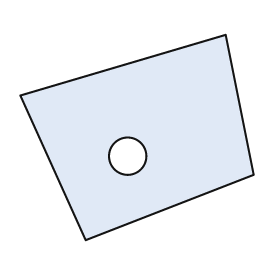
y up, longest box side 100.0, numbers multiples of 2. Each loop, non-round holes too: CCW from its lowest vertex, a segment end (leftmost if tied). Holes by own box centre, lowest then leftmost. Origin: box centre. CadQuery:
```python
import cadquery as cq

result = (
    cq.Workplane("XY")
    .moveTo(-22.0, -44.0)
    .lineTo(50.0, -16.0)
    .lineTo(38.0, 44.0)
    .lineTo(-50.0, 18.0)
    .close()
    .moveTo(-4.0, -8.0)
    .circle(8.0)
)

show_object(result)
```